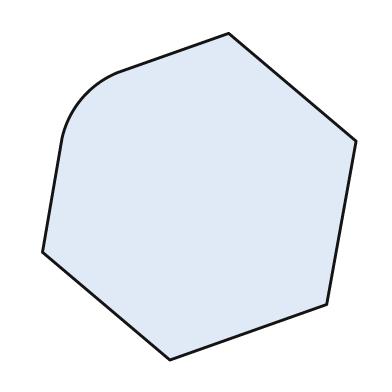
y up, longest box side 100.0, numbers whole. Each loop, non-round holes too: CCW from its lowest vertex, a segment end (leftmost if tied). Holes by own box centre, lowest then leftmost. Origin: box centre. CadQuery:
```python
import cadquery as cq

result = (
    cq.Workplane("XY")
    .moveTo(-9.0, -50.0)
    .lineTo(39.0, -33.0)
    .lineTo(48.0, 17.0)
    .lineTo(9.0, 50.0)
    .lineTo(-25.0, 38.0)
    .threePointArc((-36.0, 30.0), (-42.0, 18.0))
    .lineTo(-48.0, -17.0)
    .close()
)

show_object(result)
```